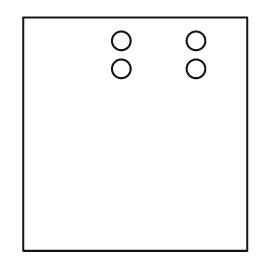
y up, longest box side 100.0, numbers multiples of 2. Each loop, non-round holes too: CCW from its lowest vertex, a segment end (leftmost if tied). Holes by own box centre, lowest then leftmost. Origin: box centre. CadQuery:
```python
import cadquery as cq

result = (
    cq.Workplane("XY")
    .moveTo(-48.0, -50.0)
    .lineTo(48.0, -50.0)
    .lineTo(48.0, 50.0)
    .lineTo(-48.0, 50.0)
    .close()
    .moveTo(-6.0, 28.0)
    .circle(4.0)
    .moveTo(26.0, 28.0)
    .circle(4.0)
    .moveTo(-6.0, 40.0)
    .circle(4.0)
    .moveTo(26.0, 40.0)
    .circle(4.0)
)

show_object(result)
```